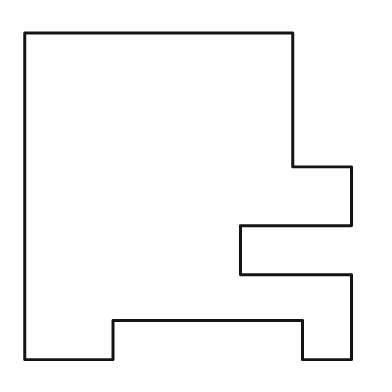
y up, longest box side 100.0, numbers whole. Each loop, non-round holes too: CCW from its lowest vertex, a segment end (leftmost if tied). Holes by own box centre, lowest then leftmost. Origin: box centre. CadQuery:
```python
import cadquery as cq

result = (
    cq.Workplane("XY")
    .moveTo(-50.0, -50.0)
    .lineTo(-23.0, -50.0)
    .lineTo(-23.0, -38.0)
    .lineTo(35.0, -38.0)
    .lineTo(35.0, -50.0)
    .lineTo(50.0, -50.0)
    .lineTo(50.0, -24.0)
    .lineTo(16.0, -24.0)
    .lineTo(16.0, -9.0)
    .lineTo(50.0, -9.0)
    .lineTo(50.0, 9.0)
    .lineTo(32.0, 9.0)
    .lineTo(32.0, 50.0)
    .lineTo(-50.0, 50.0)
    .close()
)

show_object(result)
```